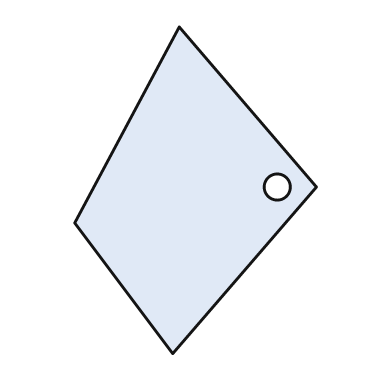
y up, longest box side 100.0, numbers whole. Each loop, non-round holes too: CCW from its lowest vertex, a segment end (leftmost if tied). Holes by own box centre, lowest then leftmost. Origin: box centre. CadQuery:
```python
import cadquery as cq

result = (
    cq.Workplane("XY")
    .moveTo(-7.0, -50.0)
    .lineTo(37.0, 1.0)
    .lineTo(-5.0, 50.0)
    .lineTo(-37.0, -10.0)
    .close()
    .moveTo(25.0, 1.0)
    .circle(4.0)
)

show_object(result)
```